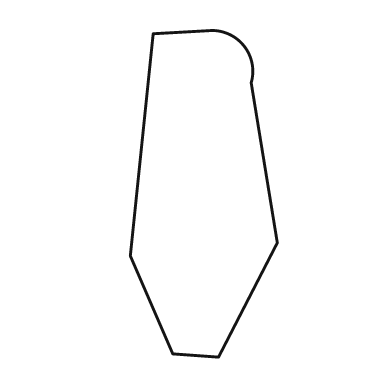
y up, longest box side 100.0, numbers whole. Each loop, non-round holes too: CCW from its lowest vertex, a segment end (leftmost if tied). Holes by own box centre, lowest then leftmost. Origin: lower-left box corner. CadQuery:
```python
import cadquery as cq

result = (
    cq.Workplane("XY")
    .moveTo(27.0, 0.0)
    .lineTo(45.0, 35.0)
    .lineTo(37.0, 84.0)
    .threePointArc((35.0, 95.0), (25.0, 100.0))
    .lineTo(7.0, 99.0)
    .lineTo(0.0, 31.0)
    .lineTo(13.0, 1.0)
    .close()
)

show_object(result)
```